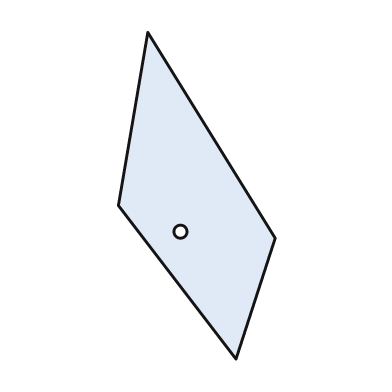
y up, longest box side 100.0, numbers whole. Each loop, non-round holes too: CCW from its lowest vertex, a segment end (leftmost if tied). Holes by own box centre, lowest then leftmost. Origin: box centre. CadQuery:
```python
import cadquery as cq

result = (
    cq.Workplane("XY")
    .moveTo(12.0, -50.0)
    .lineTo(24.0, -13.0)
    .lineTo(-15.0, 50.0)
    .lineTo(-24.0, -3.0)
    .close()
    .moveTo(-5.0, -11.0)
    .circle(2.0)
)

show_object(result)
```